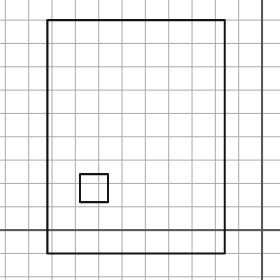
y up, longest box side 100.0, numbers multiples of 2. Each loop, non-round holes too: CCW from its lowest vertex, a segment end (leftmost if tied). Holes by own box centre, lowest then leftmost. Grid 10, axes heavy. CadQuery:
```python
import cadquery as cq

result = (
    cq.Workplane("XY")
    .moveTo(-92.0, -10.0)
    .lineTo(-16.0, -10.0)
    .lineTo(-16.0, 90.0)
    .lineTo(-92.0, 90.0)
    .close()
    .moveTo(-78.0, 12.0)
    .lineTo(-66.0, 12.0)
    .lineTo(-66.0, 24.0)
    .lineTo(-78.0, 24.0)
    .close()
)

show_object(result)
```